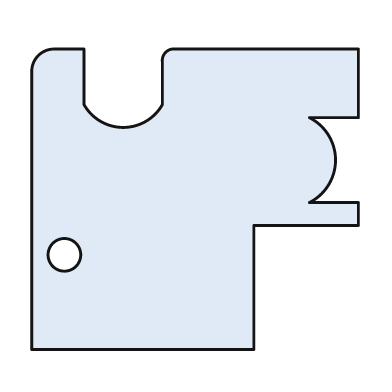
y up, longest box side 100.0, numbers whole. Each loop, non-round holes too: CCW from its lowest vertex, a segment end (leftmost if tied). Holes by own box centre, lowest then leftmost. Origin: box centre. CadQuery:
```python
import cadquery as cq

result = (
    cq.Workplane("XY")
    .moveTo(-50.0, -46.0)
    .lineTo(18.0, -46.0)
    .lineTo(18.0, -8.0)
    .lineTo(50.0, -8.0)
    .lineTo(50.0, -1.0)
    .lineTo(35.0, -1.0)
    .threePointArc((43.0, 12.0), (35.0, 25.0))
    .lineTo(50.0, 25.0)
    .lineTo(50.0, 46.0)
    .lineTo(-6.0, 46.0)
    .threePointArc((-9.0, 45.0), (-10.0, 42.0))
    .lineTo(-10.0, 29.0)
    .threePointArc((-22.0, 22.0), (-34.0, 29.0))
    .lineTo(-34.0, 46.0)
    .lineTo(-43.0, 46.0)
    .threePointArc((-48.0, 44.0), (-50.0, 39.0))
    .close()
    .moveTo(-40.0, -17.0)
    .circle(5.0)
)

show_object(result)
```